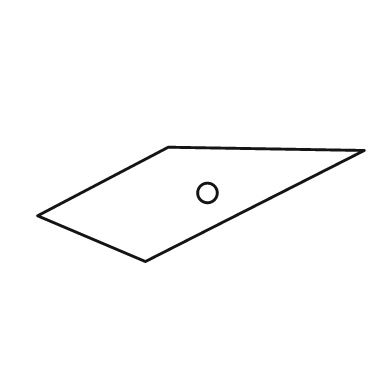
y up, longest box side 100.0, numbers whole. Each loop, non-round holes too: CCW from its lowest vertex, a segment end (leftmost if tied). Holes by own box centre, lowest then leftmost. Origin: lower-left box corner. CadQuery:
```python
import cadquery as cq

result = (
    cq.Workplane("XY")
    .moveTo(33.0, 0.0)
    .lineTo(100.0, 34.0)
    .lineTo(40.0, 35.0)
    .lineTo(0.0, 14.0)
    .close()
    .moveTo(52.0, 21.0)
    .circle(3.0)
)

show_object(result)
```